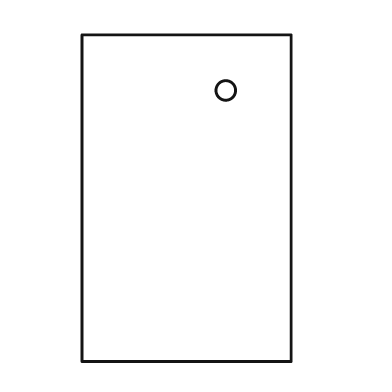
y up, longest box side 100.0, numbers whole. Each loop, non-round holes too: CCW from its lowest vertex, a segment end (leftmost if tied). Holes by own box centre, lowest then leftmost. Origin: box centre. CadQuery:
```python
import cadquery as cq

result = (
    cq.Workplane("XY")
    .moveTo(-32.0, -50.0)
    .lineTo(32.0, -50.0)
    .lineTo(32.0, 50.0)
    .lineTo(-32.0, 50.0)
    .close()
    .moveTo(12.0, 33.0)
    .circle(3.0)
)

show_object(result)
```